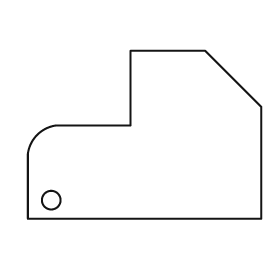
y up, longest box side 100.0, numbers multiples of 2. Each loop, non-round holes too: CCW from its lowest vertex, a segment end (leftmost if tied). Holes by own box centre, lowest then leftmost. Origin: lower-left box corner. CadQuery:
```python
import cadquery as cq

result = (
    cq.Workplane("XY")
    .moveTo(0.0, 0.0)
    .lineTo(100.0, 0.0)
    .lineTo(100.0, 48.0)
    .lineTo(76.0, 72.0)
    .lineTo(44.0, 72.0)
    .lineTo(44.0, 40.0)
    .lineTo(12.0, 40.0)
    .threePointArc((4.0, 36.0), (0.0, 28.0))
    .close()
    .moveTo(10.0, 8.0)
    .circle(4.0)
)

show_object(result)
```